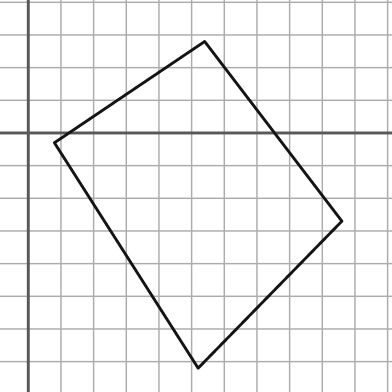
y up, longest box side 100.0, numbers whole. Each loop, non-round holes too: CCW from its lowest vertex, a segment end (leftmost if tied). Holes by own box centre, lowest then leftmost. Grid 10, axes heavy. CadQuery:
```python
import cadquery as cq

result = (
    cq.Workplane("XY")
    .moveTo(52.0, -72.0)
    .lineTo(96.0, -27.0)
    .lineTo(54.0, 28.0)
    .lineTo(8.0, -3.0)
    .close()
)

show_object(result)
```